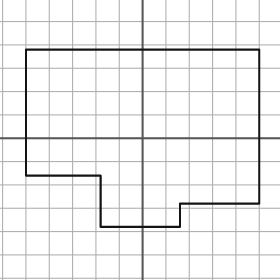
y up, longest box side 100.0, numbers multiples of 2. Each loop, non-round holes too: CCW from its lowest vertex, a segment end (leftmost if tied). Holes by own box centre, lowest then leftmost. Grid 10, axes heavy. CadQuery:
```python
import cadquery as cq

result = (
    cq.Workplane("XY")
    .moveTo(-18.0, -38.0)
    .lineTo(16.0, -38.0)
    .lineTo(16.0, -28.0)
    .lineTo(50.0, -28.0)
    .lineTo(50.0, 38.0)
    .lineTo(-50.0, 38.0)
    .lineTo(-50.0, -16.0)
    .lineTo(-18.0, -16.0)
    .close()
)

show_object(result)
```